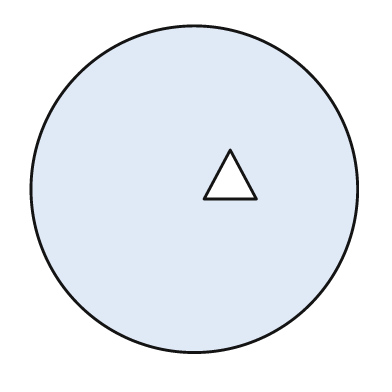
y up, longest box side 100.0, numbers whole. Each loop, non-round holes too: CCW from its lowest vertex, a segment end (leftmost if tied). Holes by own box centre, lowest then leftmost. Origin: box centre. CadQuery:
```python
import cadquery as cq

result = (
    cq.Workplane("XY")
    .moveTo(0.0, 0.0)
    .circle(50.0)
    .moveTo(3.0, -3.0)
    .lineTo(19.0, -3.0)
    .lineTo(11.0, 12.0)
    .close()
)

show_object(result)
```